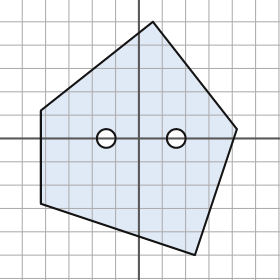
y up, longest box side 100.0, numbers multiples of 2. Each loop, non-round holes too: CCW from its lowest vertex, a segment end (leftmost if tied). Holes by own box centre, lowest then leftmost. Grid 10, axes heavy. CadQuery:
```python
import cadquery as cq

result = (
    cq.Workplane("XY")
    .moveTo(24.0, -50.0)
    .lineTo(42.0, 4.0)
    .lineTo(6.0, 50.0)
    .lineTo(-42.0, 12.0)
    .lineTo(-42.0, -28.0)
    .close()
    .moveTo(-14.0, 0.0)
    .circle(4.0)
    .moveTo(16.0, 0.0)
    .circle(4.0)
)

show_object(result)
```